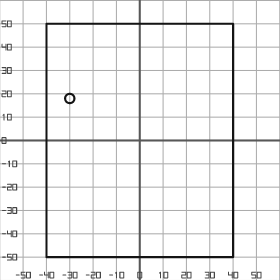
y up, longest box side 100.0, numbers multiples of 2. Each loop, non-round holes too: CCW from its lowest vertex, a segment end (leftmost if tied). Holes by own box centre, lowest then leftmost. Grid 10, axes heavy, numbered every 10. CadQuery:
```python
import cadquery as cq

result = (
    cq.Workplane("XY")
    .moveTo(-40.0, -50.0)
    .lineTo(40.0, -50.0)
    .lineTo(40.0, 50.0)
    .lineTo(-40.0, 50.0)
    .close()
    .moveTo(-30.0, 18.0)
    .circle(2.0)
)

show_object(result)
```